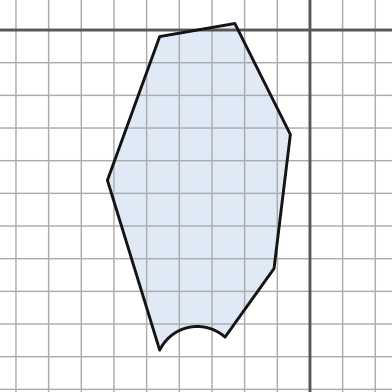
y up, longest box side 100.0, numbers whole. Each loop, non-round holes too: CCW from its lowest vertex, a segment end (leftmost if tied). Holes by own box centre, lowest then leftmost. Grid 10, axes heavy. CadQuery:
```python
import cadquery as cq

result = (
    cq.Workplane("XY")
    .moveTo(-46.0, -98.0)
    .threePointArc((-37.0, -91.0), (-26.0, -94.0))
    .lineTo(-11.0, -73.0)
    .lineTo(-6.0, -32.0)
    .lineTo(-23.0, 2.0)
    .lineTo(-46.0, -2.0)
    .lineTo(-62.0, -46.0)
    .close()
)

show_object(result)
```